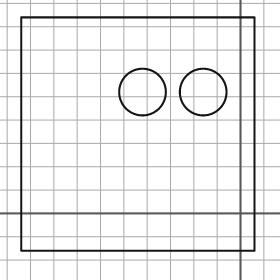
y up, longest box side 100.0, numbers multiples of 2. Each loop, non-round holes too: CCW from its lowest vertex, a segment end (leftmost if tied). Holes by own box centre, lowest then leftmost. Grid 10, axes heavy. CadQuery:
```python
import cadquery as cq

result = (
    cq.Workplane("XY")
    .moveTo(-94.0, -16.0)
    .lineTo(6.0, -16.0)
    .lineTo(6.0, 84.0)
    .lineTo(-94.0, 84.0)
    .close()
    .moveTo(-42.0, 52.0)
    .circle(10.0)
    .moveTo(-16.0, 52.0)
    .circle(10.0)
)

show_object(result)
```